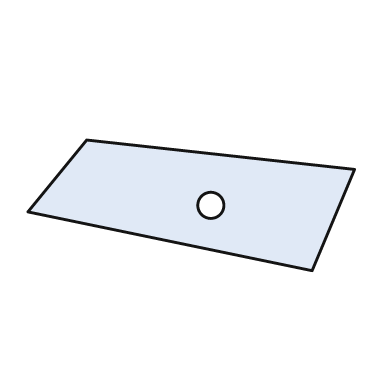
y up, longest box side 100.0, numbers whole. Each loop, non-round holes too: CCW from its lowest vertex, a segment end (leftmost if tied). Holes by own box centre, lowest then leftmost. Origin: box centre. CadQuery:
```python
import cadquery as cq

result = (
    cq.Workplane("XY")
    .moveTo(37.0, -20.0)
    .lineTo(50.0, 11.0)
    .lineTo(-32.0, 20.0)
    .lineTo(-50.0, -2.0)
    .close()
    .moveTo(6.0, 0.0)
    .circle(4.0)
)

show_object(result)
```